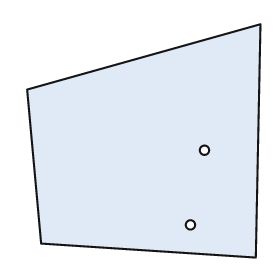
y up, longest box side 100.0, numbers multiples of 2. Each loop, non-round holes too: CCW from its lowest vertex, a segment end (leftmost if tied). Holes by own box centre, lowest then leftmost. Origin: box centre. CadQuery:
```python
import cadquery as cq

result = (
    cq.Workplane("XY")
    .moveTo(48.0, -50.0)
    .lineTo(50.0, 50.0)
    .lineTo(-50.0, 22.0)
    .lineTo(-44.0, -44.0)
    .close()
    .moveTo(20.0, -36.0)
    .circle(2.0)
    .moveTo(26.0, -4.0)
    .circle(2.0)
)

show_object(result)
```